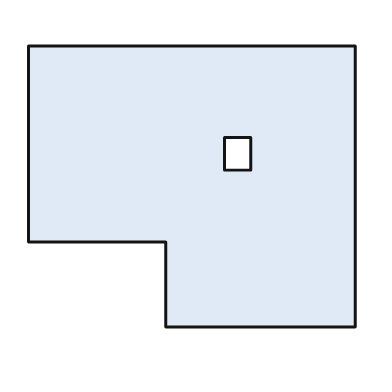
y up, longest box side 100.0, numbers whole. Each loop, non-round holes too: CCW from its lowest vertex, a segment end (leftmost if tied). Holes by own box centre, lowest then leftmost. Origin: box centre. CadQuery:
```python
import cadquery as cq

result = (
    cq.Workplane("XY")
    .moveTo(-8.0, -43.0)
    .lineTo(50.0, -43.0)
    .lineTo(50.0, 43.0)
    .lineTo(-50.0, 43.0)
    .lineTo(-50.0, -17.0)
    .lineTo(-8.0, -17.0)
    .close()
    .moveTo(10.0, 5.0)
    .lineTo(18.0, 5.0)
    .lineTo(18.0, 15.0)
    .lineTo(10.0, 15.0)
    .close()
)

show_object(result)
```